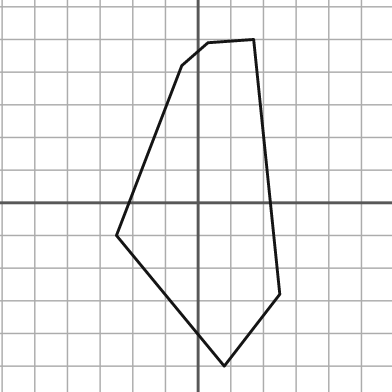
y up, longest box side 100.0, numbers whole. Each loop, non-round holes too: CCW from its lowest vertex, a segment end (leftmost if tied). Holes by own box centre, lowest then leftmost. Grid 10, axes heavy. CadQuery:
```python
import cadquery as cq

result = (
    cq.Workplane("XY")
    .moveTo(8.0, -50.0)
    .lineTo(25.0, -28.0)
    .lineTo(17.0, 50.0)
    .lineTo(3.0, 49.0)
    .lineTo(-5.0, 42.0)
    .lineTo(-25.0, -10.0)
    .close()
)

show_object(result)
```